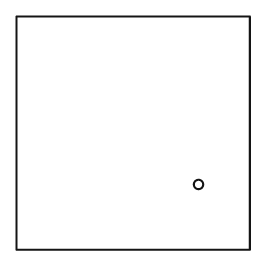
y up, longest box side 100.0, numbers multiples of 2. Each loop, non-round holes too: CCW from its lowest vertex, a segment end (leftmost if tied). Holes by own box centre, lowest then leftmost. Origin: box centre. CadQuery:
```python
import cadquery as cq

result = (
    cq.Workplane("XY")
    .moveTo(-50.0, -50.0)
    .lineTo(50.0, -50.0)
    .lineTo(50.0, 50.0)
    .lineTo(-50.0, 50.0)
    .close()
    .moveTo(28.0, -22.0)
    .circle(2.0)
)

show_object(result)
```